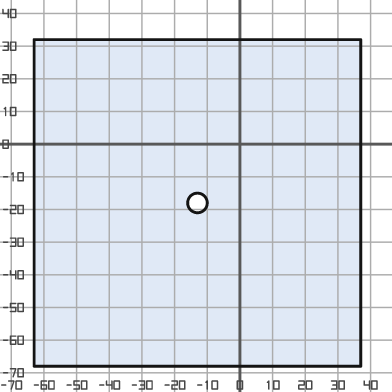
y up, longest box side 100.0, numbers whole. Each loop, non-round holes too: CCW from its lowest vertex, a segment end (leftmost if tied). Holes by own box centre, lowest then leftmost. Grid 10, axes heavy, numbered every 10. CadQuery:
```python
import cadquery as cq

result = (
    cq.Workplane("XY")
    .moveTo(-63.0, -68.0)
    .lineTo(37.0, -68.0)
    .lineTo(37.0, 32.0)
    .lineTo(-63.0, 32.0)
    .close()
    .moveTo(-13.0, -18.0)
    .circle(3.0)
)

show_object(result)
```